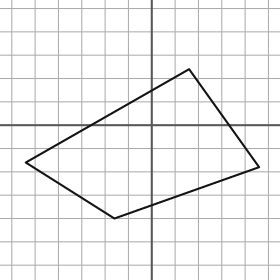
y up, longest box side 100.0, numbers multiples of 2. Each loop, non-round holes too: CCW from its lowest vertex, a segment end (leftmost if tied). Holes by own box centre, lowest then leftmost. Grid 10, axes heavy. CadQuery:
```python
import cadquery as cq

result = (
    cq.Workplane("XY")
    .moveTo(-16.0, -40.0)
    .lineTo(46.0, -18.0)
    .lineTo(16.0, 24.0)
    .lineTo(-54.0, -16.0)
    .close()
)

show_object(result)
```